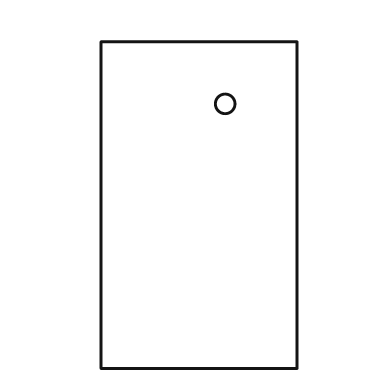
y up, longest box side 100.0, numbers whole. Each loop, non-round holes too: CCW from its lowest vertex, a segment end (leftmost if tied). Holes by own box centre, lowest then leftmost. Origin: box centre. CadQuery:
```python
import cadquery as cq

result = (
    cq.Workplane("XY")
    .moveTo(-30.0, -50.0)
    .lineTo(30.0, -50.0)
    .lineTo(30.0, 50.0)
    .lineTo(-30.0, 50.0)
    .close()
    .moveTo(8.0, 31.0)
    .circle(3.0)
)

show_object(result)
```